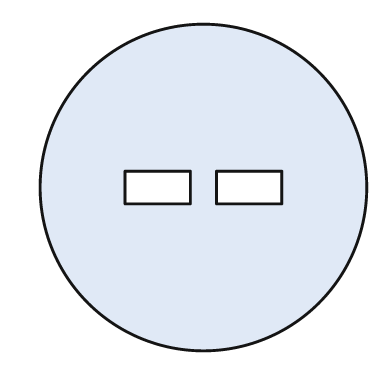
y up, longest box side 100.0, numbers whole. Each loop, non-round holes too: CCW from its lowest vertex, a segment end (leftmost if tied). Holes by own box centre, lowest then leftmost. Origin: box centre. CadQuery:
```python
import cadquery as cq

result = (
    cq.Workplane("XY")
    .moveTo(0.0, 0.0)
    .circle(50.0)
    .moveTo(-24.0, -5.0)
    .lineTo(-4.0, -5.0)
    .lineTo(-4.0, 5.0)
    .lineTo(-24.0, 5.0)
    .close()
    .moveTo(4.0, -5.0)
    .lineTo(24.0, -5.0)
    .lineTo(24.0, 5.0)
    .lineTo(4.0, 5.0)
    .close()
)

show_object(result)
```